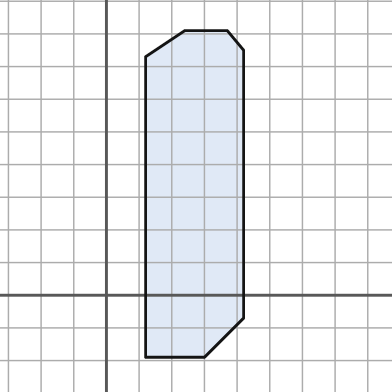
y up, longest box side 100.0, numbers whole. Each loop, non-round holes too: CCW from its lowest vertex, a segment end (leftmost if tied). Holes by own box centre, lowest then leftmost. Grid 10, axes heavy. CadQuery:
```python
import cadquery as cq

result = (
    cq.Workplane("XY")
    .moveTo(12.0, -19.0)
    .lineTo(30.0, -19.0)
    .lineTo(42.0, -7.0)
    .lineTo(42.0, 75.0)
    .lineTo(37.0, 81.0)
    .lineTo(24.0, 81.0)
    .lineTo(12.0, 73.0)
    .close()
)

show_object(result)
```